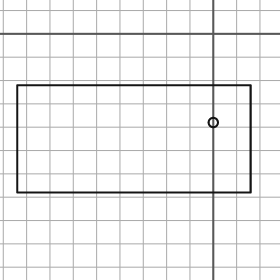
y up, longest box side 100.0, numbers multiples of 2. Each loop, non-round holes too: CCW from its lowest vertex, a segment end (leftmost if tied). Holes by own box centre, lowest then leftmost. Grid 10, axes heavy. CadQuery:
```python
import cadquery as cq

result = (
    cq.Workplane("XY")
    .moveTo(-84.0, -68.0)
    .lineTo(16.0, -68.0)
    .lineTo(16.0, -22.0)
    .lineTo(-84.0, -22.0)
    .close()
    .moveTo(0.0, -38.0)
    .circle(2.0)
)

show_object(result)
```